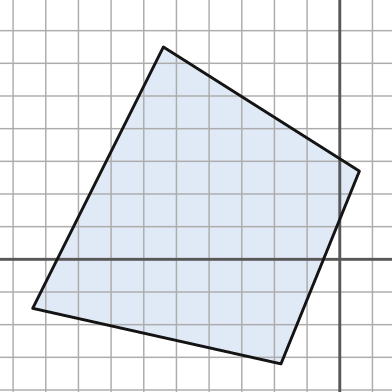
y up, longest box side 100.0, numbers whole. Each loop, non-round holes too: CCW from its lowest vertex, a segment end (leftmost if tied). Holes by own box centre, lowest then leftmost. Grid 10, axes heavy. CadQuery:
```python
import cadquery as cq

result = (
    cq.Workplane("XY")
    .moveTo(-18.0, -32.0)
    .lineTo(6.0, 27.0)
    .lineTo(-54.0, 65.0)
    .lineTo(-94.0, -15.0)
    .close()
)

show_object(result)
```